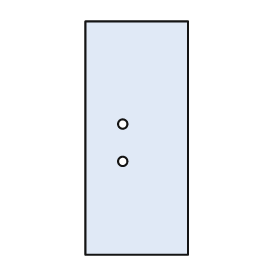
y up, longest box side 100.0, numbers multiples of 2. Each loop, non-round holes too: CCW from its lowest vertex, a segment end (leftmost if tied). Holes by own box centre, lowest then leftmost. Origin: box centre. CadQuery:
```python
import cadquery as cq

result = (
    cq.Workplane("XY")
    .moveTo(-22.0, -50.0)
    .lineTo(22.0, -50.0)
    .lineTo(22.0, 50.0)
    .lineTo(-22.0, 50.0)
    .close()
    .moveTo(-6.0, -10.0)
    .circle(2.0)
    .moveTo(-6.0, 6.0)
    .circle(2.0)
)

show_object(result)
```